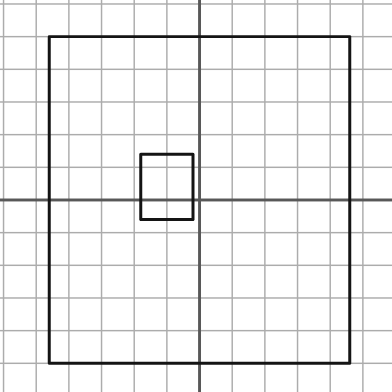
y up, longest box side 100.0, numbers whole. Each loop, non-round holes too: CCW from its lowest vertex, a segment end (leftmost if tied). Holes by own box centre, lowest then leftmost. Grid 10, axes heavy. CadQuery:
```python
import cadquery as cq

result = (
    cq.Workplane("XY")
    .moveTo(-46.0, -50.0)
    .lineTo(46.0, -50.0)
    .lineTo(46.0, 50.0)
    .lineTo(-46.0, 50.0)
    .close()
    .moveTo(-18.0, -6.0)
    .lineTo(-2.0, -6.0)
    .lineTo(-2.0, 14.0)
    .lineTo(-18.0, 14.0)
    .close()
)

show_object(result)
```